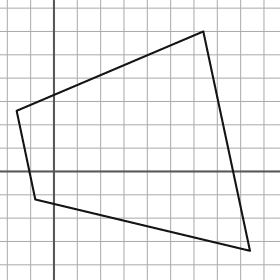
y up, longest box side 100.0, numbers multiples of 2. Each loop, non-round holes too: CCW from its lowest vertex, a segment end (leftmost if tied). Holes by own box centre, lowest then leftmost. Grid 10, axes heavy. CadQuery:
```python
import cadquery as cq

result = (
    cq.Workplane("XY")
    .moveTo(84.0, -34.0)
    .lineTo(64.0, 60.0)
    .lineTo(-16.0, 26.0)
    .lineTo(-8.0, -12.0)
    .close()
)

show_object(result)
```